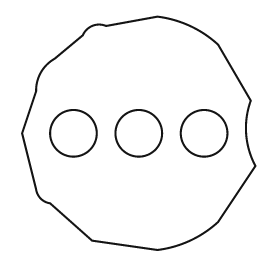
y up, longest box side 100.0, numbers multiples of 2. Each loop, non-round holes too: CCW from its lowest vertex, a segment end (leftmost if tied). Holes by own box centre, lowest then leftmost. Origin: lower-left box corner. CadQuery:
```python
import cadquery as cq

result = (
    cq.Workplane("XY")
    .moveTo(58.0, 0.0)
    .threePointArc((72.0, 4.0), (84.0, 12.0))
    .lineTo(100.0, 36.0)
    .threePointArc((96.0, 50.0), (98.0, 64.0))
    .lineTo(84.0, 88.0)
    .threePointArc((72.0, 96.0), (58.0, 100.0))
    .lineTo(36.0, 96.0)
    .threePointArc((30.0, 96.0), (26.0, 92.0))
    .lineTo(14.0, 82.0)
    .threePointArc((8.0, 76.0), (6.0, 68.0))
    .lineTo(0.0, 50.0)
    .lineTo(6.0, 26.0)
    .threePointArc((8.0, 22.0), (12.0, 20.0))
    .lineTo(30.0, 4.0)
    .close()
    .moveTo(22.0, 50.0)
    .circle(10.0)
    .moveTo(50.0, 50.0)
    .circle(10.0)
    .moveTo(78.0, 50.0)
    .circle(10.0)
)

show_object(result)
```